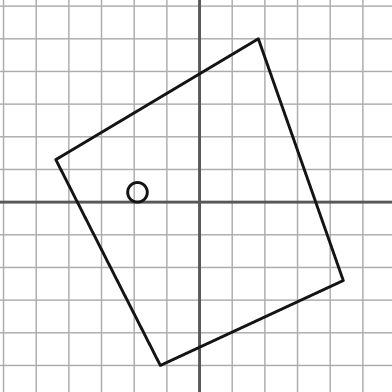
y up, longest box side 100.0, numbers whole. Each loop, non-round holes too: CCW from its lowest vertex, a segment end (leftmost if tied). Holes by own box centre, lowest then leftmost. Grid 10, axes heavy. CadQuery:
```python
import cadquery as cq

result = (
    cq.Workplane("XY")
    .moveTo(-12.0, -50.0)
    .lineTo(44.0, -24.0)
    .lineTo(18.0, 50.0)
    .lineTo(-44.0, 13.0)
    .close()
    .moveTo(-19.0, 3.0)
    .circle(3.0)
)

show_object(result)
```